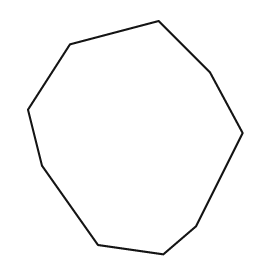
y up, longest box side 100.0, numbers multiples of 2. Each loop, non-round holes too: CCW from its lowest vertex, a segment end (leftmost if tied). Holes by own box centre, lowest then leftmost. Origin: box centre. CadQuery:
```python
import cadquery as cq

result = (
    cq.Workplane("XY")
    .moveTo(12.0, -50.0)
    .lineTo(26.0, -38.0)
    .lineTo(46.0, 2.0)
    .lineTo(32.0, 28.0)
    .lineTo(10.0, 50.0)
    .lineTo(-28.0, 40.0)
    .lineTo(-46.0, 12.0)
    .lineTo(-40.0, -12.0)
    .lineTo(-16.0, -46.0)
    .close()
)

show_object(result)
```